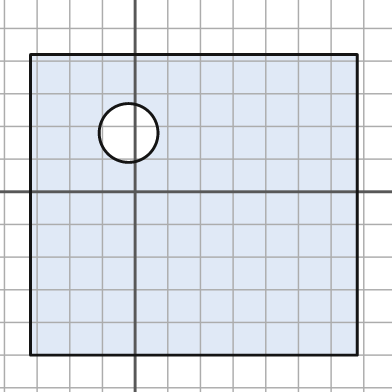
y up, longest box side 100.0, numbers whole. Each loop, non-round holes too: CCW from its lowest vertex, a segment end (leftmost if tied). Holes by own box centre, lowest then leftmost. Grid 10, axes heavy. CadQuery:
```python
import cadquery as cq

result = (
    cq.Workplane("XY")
    .moveTo(-32.0, -50.0)
    .lineTo(68.0, -50.0)
    .lineTo(68.0, 42.0)
    .lineTo(-32.0, 42.0)
    .close()
    .moveTo(-2.0, 18.0)
    .circle(9.0)
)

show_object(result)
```